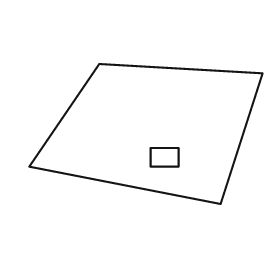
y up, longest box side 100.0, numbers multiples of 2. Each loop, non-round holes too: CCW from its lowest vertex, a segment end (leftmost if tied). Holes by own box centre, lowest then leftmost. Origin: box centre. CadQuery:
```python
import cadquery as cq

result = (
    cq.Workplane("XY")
    .moveTo(32.0, -30.0)
    .lineTo(50.0, 26.0)
    .lineTo(-20.0, 30.0)
    .lineTo(-50.0, -14.0)
    .close()
    .moveTo(2.0, -14.0)
    .lineTo(14.0, -14.0)
    .lineTo(14.0, -6.0)
    .lineTo(2.0, -6.0)
    .close()
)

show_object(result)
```